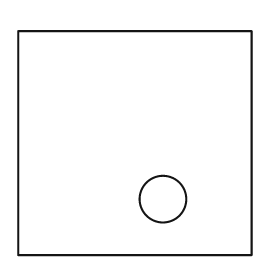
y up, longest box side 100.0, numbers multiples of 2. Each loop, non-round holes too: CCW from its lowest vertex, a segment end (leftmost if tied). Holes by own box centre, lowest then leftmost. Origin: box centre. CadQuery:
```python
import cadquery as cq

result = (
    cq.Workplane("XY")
    .moveTo(-50.0, -48.0)
    .lineTo(50.0, -48.0)
    .lineTo(50.0, 48.0)
    .lineTo(-50.0, 48.0)
    .close()
    .moveTo(12.0, -24.0)
    .circle(10.0)
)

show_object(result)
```